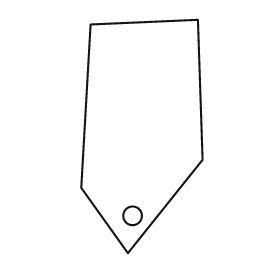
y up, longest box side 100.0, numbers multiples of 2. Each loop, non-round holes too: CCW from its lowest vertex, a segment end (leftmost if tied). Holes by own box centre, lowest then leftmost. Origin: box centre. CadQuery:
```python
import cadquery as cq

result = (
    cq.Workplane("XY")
    .moveTo(-6.0, -50.0)
    .lineTo(26.0, -10.0)
    .lineTo(24.0, 50.0)
    .lineTo(-22.0, 48.0)
    .lineTo(-26.0, -22.0)
    .close()
    .moveTo(-4.0, -34.0)
    .circle(4.0)
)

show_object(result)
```